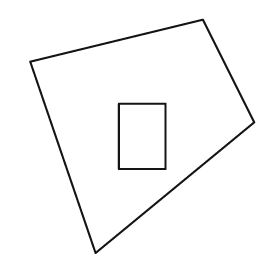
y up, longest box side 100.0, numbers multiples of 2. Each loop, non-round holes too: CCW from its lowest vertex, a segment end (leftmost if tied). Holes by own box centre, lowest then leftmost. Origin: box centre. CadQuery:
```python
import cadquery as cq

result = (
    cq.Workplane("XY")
    .moveTo(-20.0, -50.0)
    .lineTo(48.0, 6.0)
    .lineTo(26.0, 50.0)
    .lineTo(-48.0, 32.0)
    .close()
    .moveTo(-10.0, -14.0)
    .lineTo(10.0, -14.0)
    .lineTo(10.0, 14.0)
    .lineTo(-10.0, 14.0)
    .close()
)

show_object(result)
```